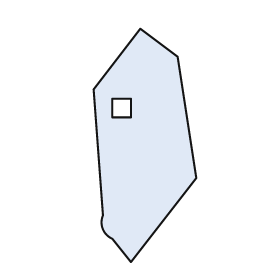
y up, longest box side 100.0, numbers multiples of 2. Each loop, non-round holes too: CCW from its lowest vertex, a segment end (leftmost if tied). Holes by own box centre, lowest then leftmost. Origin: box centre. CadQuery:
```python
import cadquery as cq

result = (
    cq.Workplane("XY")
    .moveTo(-6.0, -50.0)
    .lineTo(22.0, -14.0)
    .lineTo(14.0, 38.0)
    .lineTo(-2.0, 50.0)
    .lineTo(-22.0, 24.0)
    .lineTo(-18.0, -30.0)
    .threePointArc((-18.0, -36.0), (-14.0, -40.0))
    .close()
    .moveTo(-14.0, 12.0)
    .lineTo(-6.0, 12.0)
    .lineTo(-6.0, 20.0)
    .lineTo(-14.0, 20.0)
    .close()
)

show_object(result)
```